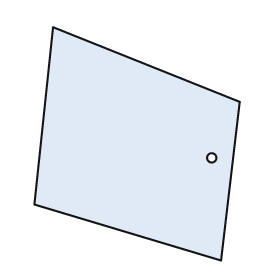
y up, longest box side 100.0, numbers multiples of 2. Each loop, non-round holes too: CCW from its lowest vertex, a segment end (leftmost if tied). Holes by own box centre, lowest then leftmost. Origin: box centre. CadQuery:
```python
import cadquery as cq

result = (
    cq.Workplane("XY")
    .moveTo(36.0, -50.0)
    .lineTo(44.0, 18.0)
    .lineTo(-36.0, 50.0)
    .lineTo(-44.0, -26.0)
    .close()
    .moveTo(32.0, -6.0)
    .circle(2.0)
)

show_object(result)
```